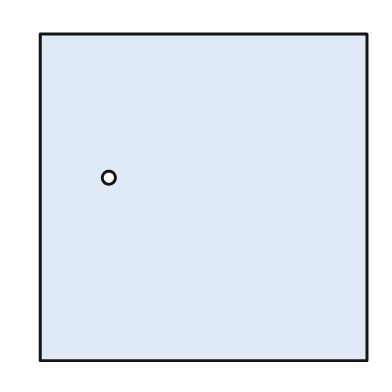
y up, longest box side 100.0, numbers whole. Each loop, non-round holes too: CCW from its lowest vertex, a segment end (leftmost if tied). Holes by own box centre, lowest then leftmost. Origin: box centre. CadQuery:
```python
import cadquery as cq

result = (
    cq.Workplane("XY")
    .moveTo(-50.0, -50.0)
    .lineTo(50.0, -50.0)
    .lineTo(50.0, 50.0)
    .lineTo(-50.0, 50.0)
    .close()
    .moveTo(-29.0, 6.0)
    .circle(2.0)
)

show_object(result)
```